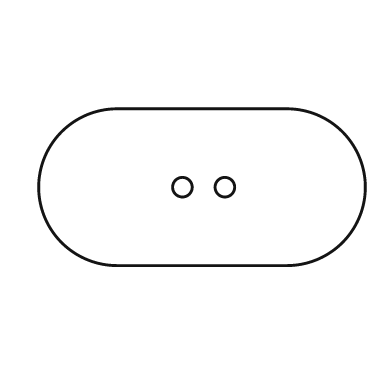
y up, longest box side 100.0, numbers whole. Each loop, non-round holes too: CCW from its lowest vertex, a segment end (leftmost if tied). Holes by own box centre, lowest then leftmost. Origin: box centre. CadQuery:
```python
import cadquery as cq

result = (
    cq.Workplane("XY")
    .moveTo(-26.0, -24.0)
    .lineTo(26.0, -24.0)
    .threePointArc((50.0, 0.0), (26.0, 24.0))
    .lineTo(-26.0, 24.0)
    .threePointArc((-50.0, 0.0), (-26.0, -24.0))
    .close()
    .moveTo(-6.0, 0.0)
    .circle(3.0)
    .moveTo(7.0, 0.0)
    .circle(3.0)
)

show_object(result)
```